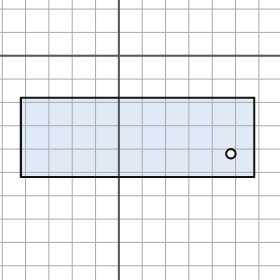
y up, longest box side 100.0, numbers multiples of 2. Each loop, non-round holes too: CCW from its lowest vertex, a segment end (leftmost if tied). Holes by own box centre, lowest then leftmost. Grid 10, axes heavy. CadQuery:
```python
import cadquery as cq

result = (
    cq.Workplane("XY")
    .moveTo(-42.0, -52.0)
    .lineTo(58.0, -52.0)
    .lineTo(58.0, -18.0)
    .lineTo(-42.0, -18.0)
    .close()
    .moveTo(48.0, -42.0)
    .circle(2.0)
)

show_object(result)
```